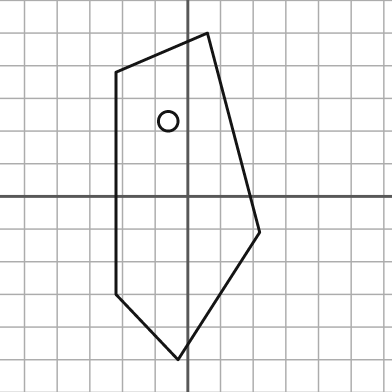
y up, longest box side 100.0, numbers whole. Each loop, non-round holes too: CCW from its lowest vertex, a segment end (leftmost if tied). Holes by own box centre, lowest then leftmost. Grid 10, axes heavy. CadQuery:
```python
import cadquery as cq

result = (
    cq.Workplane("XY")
    .moveTo(-3.0, -50.0)
    .lineTo(22.0, -11.0)
    .lineTo(6.0, 50.0)
    .lineTo(-22.0, 38.0)
    .lineTo(-22.0, -30.0)
    .close()
    .moveTo(-6.0, 23.0)
    .circle(3.0)
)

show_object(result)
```